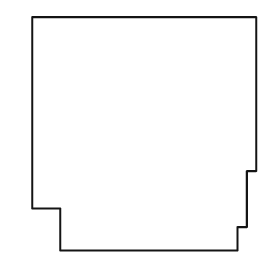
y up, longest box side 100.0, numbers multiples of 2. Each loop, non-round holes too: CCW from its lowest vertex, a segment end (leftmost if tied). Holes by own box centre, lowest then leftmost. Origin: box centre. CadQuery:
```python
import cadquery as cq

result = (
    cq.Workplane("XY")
    .moveTo(-36.0, -50.0)
    .lineTo(40.0, -50.0)
    .lineTo(40.0, -40.0)
    .lineTo(44.0, -40.0)
    .lineTo(44.0, -16.0)
    .lineTo(48.0, -16.0)
    .lineTo(48.0, 50.0)
    .lineTo(-48.0, 50.0)
    .lineTo(-48.0, -32.0)
    .lineTo(-36.0, -32.0)
    .close()
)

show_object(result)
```